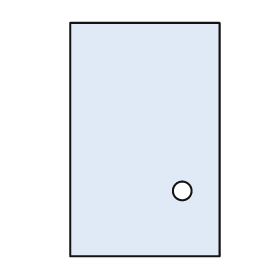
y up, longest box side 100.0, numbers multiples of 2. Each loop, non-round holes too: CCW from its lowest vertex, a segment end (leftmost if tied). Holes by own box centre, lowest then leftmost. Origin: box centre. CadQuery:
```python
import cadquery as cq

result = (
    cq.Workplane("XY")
    .moveTo(-32.0, -50.0)
    .lineTo(32.0, -50.0)
    .lineTo(32.0, 50.0)
    .lineTo(-32.0, 50.0)
    .close()
    .moveTo(16.0, -22.0)
    .circle(4.0)
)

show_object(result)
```